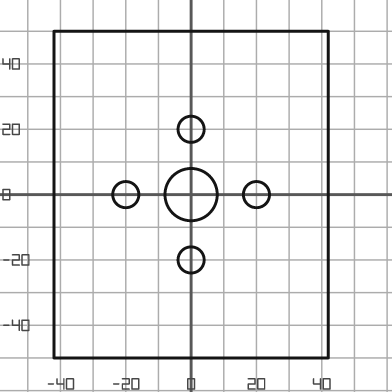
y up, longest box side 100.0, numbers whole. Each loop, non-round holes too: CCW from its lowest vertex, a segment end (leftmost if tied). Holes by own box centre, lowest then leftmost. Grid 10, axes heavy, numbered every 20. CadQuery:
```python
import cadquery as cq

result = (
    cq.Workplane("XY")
    .moveTo(-42.0, -50.0)
    .lineTo(42.0, -50.0)
    .lineTo(42.0, 50.0)
    .lineTo(-42.0, 50.0)
    .close()
    .moveTo(0.0, -20.0)
    .circle(4.0)
    .moveTo(-20.0, 0.0)
    .circle(4.0)
    .moveTo(0.0, 0.0)
    .circle(8.0)
    .moveTo(20.0, 0.0)
    .circle(4.0)
    .moveTo(0.0, 20.0)
    .circle(4.0)
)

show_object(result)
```